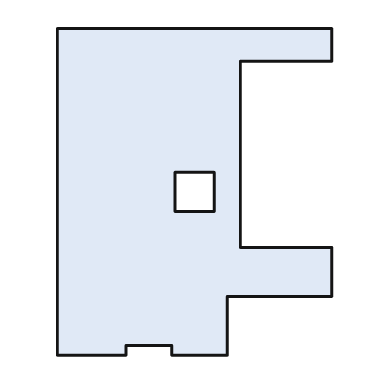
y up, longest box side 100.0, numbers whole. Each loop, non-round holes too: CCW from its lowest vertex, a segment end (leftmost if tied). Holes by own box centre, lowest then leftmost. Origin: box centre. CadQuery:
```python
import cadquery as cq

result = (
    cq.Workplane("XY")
    .moveTo(-42.0, -50.0)
    .lineTo(-21.0, -50.0)
    .lineTo(-21.0, -47.0)
    .lineTo(-7.0, -47.0)
    .lineTo(-7.0, -50.0)
    .lineTo(10.0, -50.0)
    .lineTo(10.0, -32.0)
    .lineTo(42.0, -32.0)
    .lineTo(42.0, -17.0)
    .lineTo(14.0, -17.0)
    .lineTo(14.0, 40.0)
    .lineTo(42.0, 40.0)
    .lineTo(42.0, 50.0)
    .lineTo(-42.0, 50.0)
    .close()
    .moveTo(-6.0, -6.0)
    .lineTo(6.0, -6.0)
    .lineTo(6.0, 6.0)
    .lineTo(-6.0, 6.0)
    .close()
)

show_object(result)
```